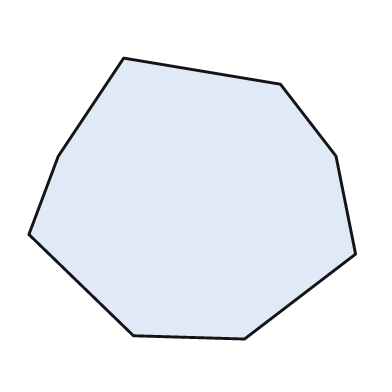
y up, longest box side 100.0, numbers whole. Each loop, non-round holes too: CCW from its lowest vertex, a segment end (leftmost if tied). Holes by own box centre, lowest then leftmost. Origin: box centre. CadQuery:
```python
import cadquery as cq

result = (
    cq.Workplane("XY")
    .moveTo(16.0, -43.0)
    .lineTo(50.0, -17.0)
    .lineTo(44.0, 13.0)
    .lineTo(27.0, 35.0)
    .lineTo(-21.0, 43.0)
    .lineTo(-41.0, 13.0)
    .lineTo(-50.0, -11.0)
    .lineTo(-18.0, -42.0)
    .close()
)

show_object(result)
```